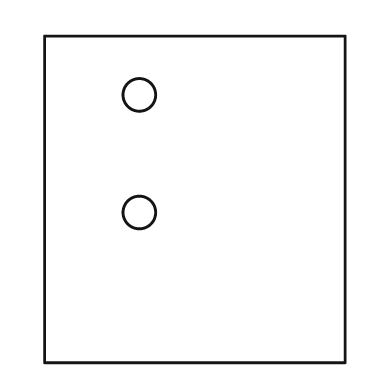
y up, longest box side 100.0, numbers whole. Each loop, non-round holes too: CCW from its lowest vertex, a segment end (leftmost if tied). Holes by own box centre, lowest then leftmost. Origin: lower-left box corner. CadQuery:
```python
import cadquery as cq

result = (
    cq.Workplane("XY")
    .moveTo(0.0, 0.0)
    .lineTo(92.0, 0.0)
    .lineTo(92.0, 100.0)
    .lineTo(0.0, 100.0)
    .close()
    .moveTo(29.0, 46.0)
    .circle(5.0)
    .moveTo(29.0, 82.0)
    .circle(5.0)
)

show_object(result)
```